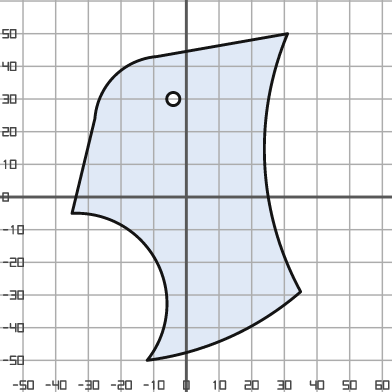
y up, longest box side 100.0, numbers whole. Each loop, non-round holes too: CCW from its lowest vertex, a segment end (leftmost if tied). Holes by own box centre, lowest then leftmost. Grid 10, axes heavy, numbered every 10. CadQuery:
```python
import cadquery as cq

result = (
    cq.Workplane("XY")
    .moveTo(-12.0, -50.0)
    .threePointArc((13.0, -43.0), (35.0, -29.0))
    .threePointArc((24.0, 10.0), (31.0, 50.0))
    .lineTo(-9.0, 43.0)
    .threePointArc((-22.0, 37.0), (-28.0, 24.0))
    .lineTo(-35.0, -5.0)
    .threePointArc((-9.0, -20.0), (-12.0, -50.0))
    .close()
    .moveTo(-4.0, 30.0)
    .circle(2.0)
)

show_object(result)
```